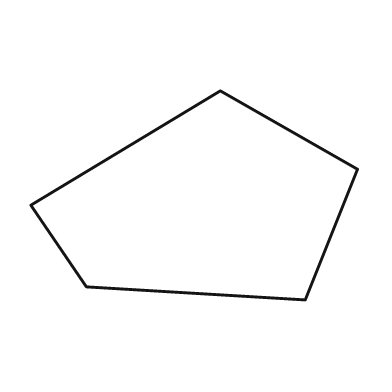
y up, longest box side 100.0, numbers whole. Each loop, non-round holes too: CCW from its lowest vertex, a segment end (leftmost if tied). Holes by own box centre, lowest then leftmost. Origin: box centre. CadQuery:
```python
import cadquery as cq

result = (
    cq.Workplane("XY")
    .moveTo(34.0, -32.0)
    .lineTo(50.0, 8.0)
    .lineTo(8.0, 32.0)
    .lineTo(-50.0, -3.0)
    .lineTo(-33.0, -28.0)
    .close()
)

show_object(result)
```